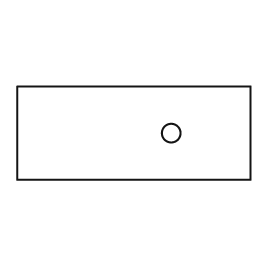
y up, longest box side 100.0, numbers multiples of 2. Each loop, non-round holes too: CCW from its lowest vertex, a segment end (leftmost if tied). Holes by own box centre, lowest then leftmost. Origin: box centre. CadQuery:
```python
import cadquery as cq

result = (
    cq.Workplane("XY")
    .moveTo(-50.0, -20.0)
    .lineTo(50.0, -20.0)
    .lineTo(50.0, 20.0)
    .lineTo(-50.0, 20.0)
    .close()
    .moveTo(16.0, 0.0)
    .circle(4.0)
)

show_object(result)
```